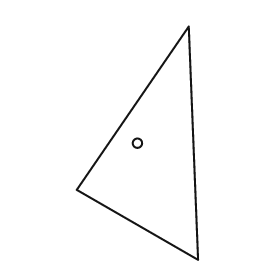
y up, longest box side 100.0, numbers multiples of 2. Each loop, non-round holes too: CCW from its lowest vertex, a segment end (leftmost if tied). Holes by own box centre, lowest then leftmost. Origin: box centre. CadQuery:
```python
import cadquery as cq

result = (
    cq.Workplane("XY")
    .moveTo(26.0, -50.0)
    .lineTo(22.0, 50.0)
    .lineTo(-26.0, -20.0)
    .close()
    .moveTo(0.0, 0.0)
    .circle(2.0)
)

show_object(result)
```